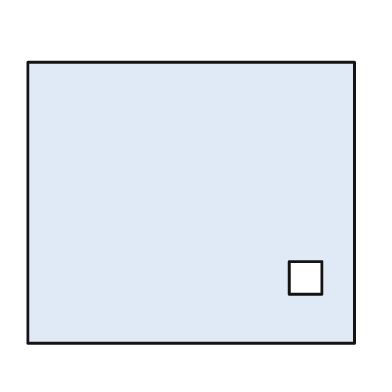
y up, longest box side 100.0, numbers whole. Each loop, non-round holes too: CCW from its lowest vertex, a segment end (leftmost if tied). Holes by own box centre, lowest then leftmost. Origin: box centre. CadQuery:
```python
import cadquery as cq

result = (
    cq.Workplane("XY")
    .moveTo(-50.0, -43.0)
    .lineTo(50.0, -43.0)
    .lineTo(50.0, 43.0)
    .lineTo(-50.0, 43.0)
    .close()
    .moveTo(30.0, -28.0)
    .lineTo(40.0, -28.0)
    .lineTo(40.0, -18.0)
    .lineTo(30.0, -18.0)
    .close()
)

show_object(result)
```